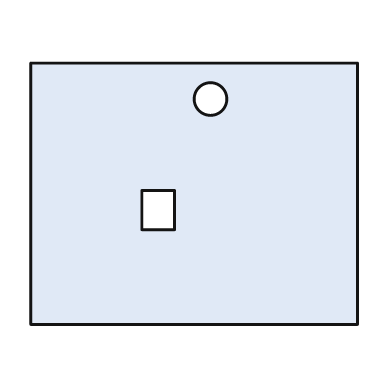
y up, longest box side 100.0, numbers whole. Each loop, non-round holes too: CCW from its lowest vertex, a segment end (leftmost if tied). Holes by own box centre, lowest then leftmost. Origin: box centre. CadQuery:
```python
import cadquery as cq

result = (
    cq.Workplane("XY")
    .moveTo(-50.0, -40.0)
    .lineTo(50.0, -40.0)
    .lineTo(50.0, 40.0)
    .lineTo(-50.0, 40.0)
    .close()
    .moveTo(-16.0, -11.0)
    .lineTo(-6.0, -11.0)
    .lineTo(-6.0, 1.0)
    .lineTo(-16.0, 1.0)
    .close()
    .moveTo(5.0, 29.0)
    .circle(5.0)
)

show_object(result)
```